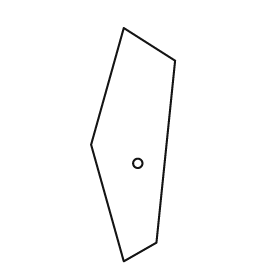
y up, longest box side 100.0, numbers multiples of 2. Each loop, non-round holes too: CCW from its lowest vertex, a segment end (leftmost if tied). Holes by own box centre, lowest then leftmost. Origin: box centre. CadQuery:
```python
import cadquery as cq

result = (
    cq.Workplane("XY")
    .moveTo(-4.0, -50.0)
    .lineTo(10.0, -42.0)
    .lineTo(18.0, 36.0)
    .lineTo(-4.0, 50.0)
    .lineTo(-18.0, 0.0)
    .close()
    .moveTo(2.0, -8.0)
    .circle(2.0)
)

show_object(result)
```